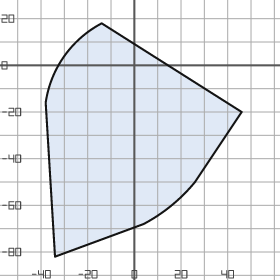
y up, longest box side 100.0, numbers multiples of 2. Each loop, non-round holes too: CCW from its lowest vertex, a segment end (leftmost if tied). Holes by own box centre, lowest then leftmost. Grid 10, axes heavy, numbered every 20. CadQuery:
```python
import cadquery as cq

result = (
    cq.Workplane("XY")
    .moveTo(-34.0, -82.0)
    .lineTo(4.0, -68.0)
    .threePointArc((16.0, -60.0), (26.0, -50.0))
    .lineTo(46.0, -20.0)
    .lineTo(-14.0, 18.0)
    .threePointArc((-30.0, 4.0), (-38.0, -16.0))
    .close()
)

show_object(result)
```